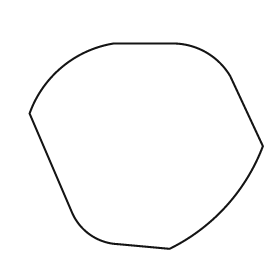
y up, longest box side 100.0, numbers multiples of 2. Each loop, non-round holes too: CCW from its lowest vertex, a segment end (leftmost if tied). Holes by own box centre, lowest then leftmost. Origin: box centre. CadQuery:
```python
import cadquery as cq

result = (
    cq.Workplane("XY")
    .moveTo(10.0, -44.0)
    .threePointArc((34.0, -26.0), (50.0, 0.0))
    .lineTo(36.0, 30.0)
    .threePointArc((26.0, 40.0), (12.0, 44.0))
    .lineTo(-14.0, 44.0)
    .threePointArc((-36.0, 34.0), (-50.0, 14.0))
    .lineTo(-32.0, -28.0)
    .threePointArc((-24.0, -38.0), (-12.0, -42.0))
    .close()
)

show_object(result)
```